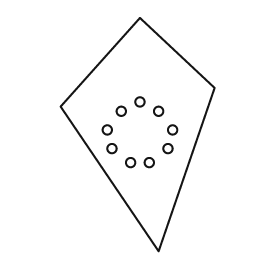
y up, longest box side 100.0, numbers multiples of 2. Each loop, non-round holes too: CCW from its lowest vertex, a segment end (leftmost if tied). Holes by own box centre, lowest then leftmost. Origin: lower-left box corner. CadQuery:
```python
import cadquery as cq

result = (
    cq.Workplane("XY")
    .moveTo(42.0, 0.0)
    .lineTo(66.0, 70.0)
    .lineTo(34.0, 100.0)
    .lineTo(0.0, 62.0)
    .close()
    .moveTo(30.0, 38.0)
    .circle(2.0)
    .moveTo(38.0, 38.0)
    .circle(2.0)
    .moveTo(22.0, 44.0)
    .circle(2.0)
    .moveTo(46.0, 44.0)
    .circle(2.0)
    .moveTo(20.0, 52.0)
    .circle(2.0)
    .moveTo(48.0, 52.0)
    .circle(2.0)
    .moveTo(26.0, 60.0)
    .circle(2.0)
    .moveTo(42.0, 60.0)
    .circle(2.0)
    .moveTo(34.0, 64.0)
    .circle(2.0)
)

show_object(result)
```